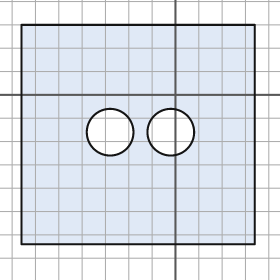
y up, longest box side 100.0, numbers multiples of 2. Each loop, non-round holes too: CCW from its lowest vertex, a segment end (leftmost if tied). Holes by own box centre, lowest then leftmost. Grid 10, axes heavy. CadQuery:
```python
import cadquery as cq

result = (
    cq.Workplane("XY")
    .moveTo(-66.0, -64.0)
    .lineTo(34.0, -64.0)
    .lineTo(34.0, 30.0)
    .lineTo(-66.0, 30.0)
    .close()
    .moveTo(-28.0, -16.0)
    .circle(10.0)
    .moveTo(-2.0, -16.0)
    .circle(10.0)
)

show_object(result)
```